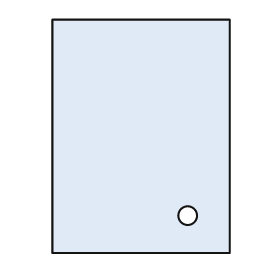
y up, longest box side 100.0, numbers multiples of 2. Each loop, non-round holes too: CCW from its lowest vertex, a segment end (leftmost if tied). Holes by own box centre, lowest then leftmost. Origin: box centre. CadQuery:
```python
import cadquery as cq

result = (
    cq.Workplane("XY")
    .moveTo(-38.0, -50.0)
    .lineTo(38.0, -50.0)
    .lineTo(38.0, 50.0)
    .lineTo(-38.0, 50.0)
    .close()
    .moveTo(20.0, -34.0)
    .circle(4.0)
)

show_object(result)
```